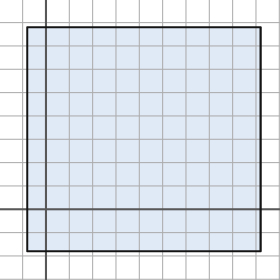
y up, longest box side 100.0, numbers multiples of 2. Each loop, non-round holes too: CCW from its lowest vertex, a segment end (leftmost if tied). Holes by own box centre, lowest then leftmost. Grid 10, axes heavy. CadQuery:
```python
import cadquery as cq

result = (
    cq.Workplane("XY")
    .moveTo(-8.0, -18.0)
    .lineTo(92.0, -18.0)
    .lineTo(92.0, 78.0)
    .lineTo(-8.0, 78.0)
    .close()
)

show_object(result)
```